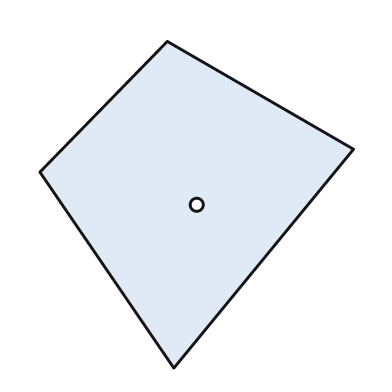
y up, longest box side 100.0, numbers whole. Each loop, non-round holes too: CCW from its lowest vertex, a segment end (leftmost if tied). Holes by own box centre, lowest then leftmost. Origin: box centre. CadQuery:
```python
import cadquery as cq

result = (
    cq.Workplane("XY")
    .moveTo(-7.0, -50.0)
    .lineTo(48.0, 17.0)
    .lineTo(-9.0, 50.0)
    .lineTo(-48.0, 10.0)
    .close()
    .moveTo(0.0, 0.0)
    .circle(2.0)
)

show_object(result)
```